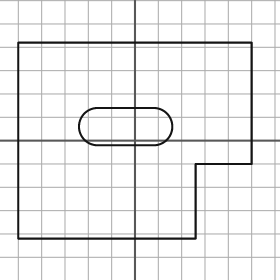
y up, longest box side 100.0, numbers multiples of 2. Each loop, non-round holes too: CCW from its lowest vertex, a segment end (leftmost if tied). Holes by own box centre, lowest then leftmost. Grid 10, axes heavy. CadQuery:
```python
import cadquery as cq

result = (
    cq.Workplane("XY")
    .moveTo(-50.0, -42.0)
    .lineTo(26.0, -42.0)
    .lineTo(26.0, -10.0)
    .lineTo(50.0, -10.0)
    .lineTo(50.0, 42.0)
    .lineTo(-50.0, 42.0)
    .close()
    .moveTo(-16.0, -2.0)
    .lineTo(8.0, -2.0)
    .threePointArc((16.0, 6.0), (8.0, 14.0))
    .lineTo(-16.0, 14.0)
    .threePointArc((-24.0, 6.0), (-16.0, -2.0))
    .close()
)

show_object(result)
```